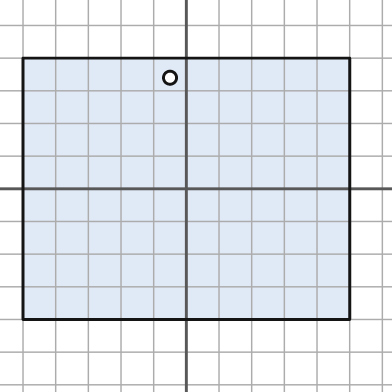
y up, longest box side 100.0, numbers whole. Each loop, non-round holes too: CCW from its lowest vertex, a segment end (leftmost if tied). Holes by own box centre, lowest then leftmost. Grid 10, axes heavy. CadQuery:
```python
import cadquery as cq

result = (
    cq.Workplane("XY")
    .moveTo(-50.0, -40.0)
    .lineTo(50.0, -40.0)
    .lineTo(50.0, 40.0)
    .lineTo(-50.0, 40.0)
    .close()
    .moveTo(-5.0, 34.0)
    .circle(2.0)
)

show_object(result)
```